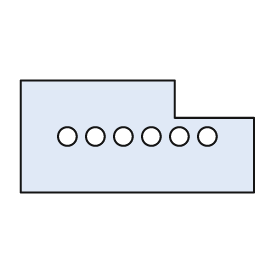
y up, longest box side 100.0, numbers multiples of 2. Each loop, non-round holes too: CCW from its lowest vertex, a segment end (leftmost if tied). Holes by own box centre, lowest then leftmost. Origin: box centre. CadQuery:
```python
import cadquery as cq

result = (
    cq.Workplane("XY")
    .moveTo(-50.0, -24.0)
    .lineTo(50.0, -24.0)
    .lineTo(50.0, 8.0)
    .lineTo(16.0, 8.0)
    .lineTo(16.0, 24.0)
    .lineTo(-50.0, 24.0)
    .close()
    .moveTo(-30.0, 0.0)
    .circle(4.0)
    .moveTo(-18.0, 0.0)
    .circle(4.0)
    .moveTo(-6.0, 0.0)
    .circle(4.0)
    .moveTo(6.0, 0.0)
    .circle(4.0)
    .moveTo(18.0, 0.0)
    .circle(4.0)
    .moveTo(30.0, 0.0)
    .circle(4.0)
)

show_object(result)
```